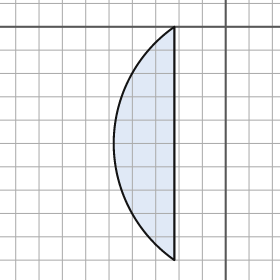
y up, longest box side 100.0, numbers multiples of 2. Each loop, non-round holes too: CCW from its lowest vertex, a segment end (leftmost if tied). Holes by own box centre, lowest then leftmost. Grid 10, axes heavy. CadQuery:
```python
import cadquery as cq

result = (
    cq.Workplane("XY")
    .moveTo(-22.0, -100.0)
    .lineTo(-22.0, 0.0)
    .threePointArc((-48.0, -50.0), (-22.0, -100.0))
    .close()
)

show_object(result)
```